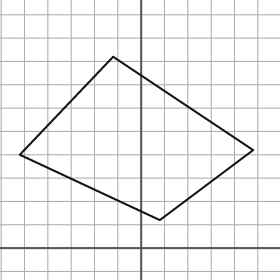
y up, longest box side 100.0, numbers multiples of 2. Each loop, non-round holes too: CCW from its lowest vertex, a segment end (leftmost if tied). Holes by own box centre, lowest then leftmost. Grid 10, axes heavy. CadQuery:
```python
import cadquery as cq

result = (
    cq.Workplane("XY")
    .moveTo(8.0, 12.0)
    .lineTo(48.0, 42.0)
    .lineTo(-12.0, 82.0)
    .lineTo(-52.0, 40.0)
    .close()
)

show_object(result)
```